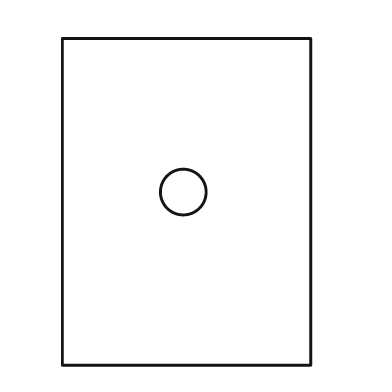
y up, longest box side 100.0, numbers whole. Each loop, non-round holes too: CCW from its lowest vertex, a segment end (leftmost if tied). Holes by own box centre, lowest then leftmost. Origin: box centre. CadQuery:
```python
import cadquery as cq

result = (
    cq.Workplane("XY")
    .moveTo(-38.0, -50.0)
    .lineTo(38.0, -50.0)
    .lineTo(38.0, 50.0)
    .lineTo(-38.0, 50.0)
    .close()
    .moveTo(-1.0, 3.0)
    .circle(7.0)
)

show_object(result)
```